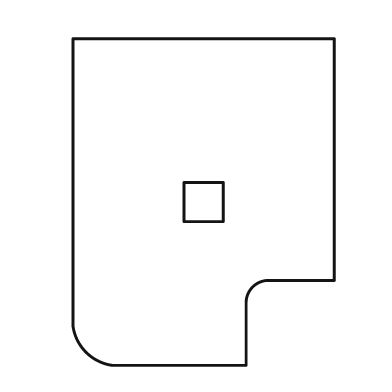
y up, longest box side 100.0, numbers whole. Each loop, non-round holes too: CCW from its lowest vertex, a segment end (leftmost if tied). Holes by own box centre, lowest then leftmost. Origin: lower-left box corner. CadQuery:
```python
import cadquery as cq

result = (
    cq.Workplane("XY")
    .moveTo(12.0, 0.0)
    .lineTo(53.0, 0.0)
    .lineTo(53.0, 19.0)
    .threePointArc((55.0, 24.0), (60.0, 26.0))
    .lineTo(80.0, 26.0)
    .lineTo(80.0, 100.0)
    .lineTo(0.0, 100.0)
    .lineTo(0.0, 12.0)
    .threePointArc((4.0, 4.0), (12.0, 0.0))
    .close()
    .moveTo(34.0, 44.0)
    .lineTo(46.0, 44.0)
    .lineTo(46.0, 56.0)
    .lineTo(34.0, 56.0)
    .close()
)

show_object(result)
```